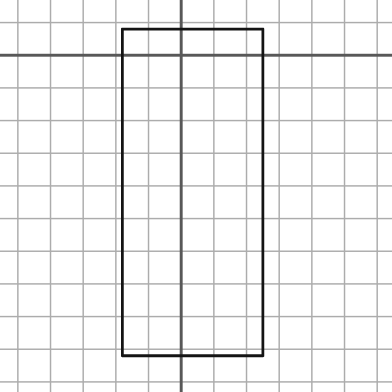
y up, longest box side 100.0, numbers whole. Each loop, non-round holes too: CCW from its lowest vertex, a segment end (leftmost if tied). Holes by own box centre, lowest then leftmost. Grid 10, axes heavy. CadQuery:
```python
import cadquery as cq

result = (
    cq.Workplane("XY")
    .moveTo(-18.0, -92.0)
    .lineTo(25.0, -92.0)
    .lineTo(25.0, 8.0)
    .lineTo(-18.0, 8.0)
    .close()
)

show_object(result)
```